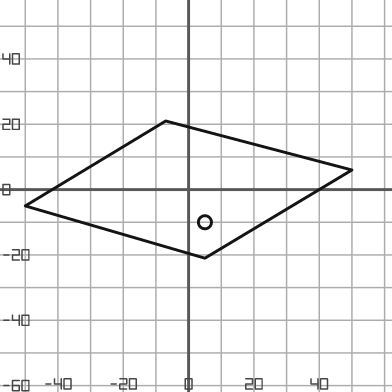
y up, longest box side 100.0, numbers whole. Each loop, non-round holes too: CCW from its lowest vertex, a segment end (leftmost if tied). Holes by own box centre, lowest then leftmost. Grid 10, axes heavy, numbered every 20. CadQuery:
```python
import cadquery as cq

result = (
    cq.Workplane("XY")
    .moveTo(5.0, -21.0)
    .lineTo(50.0, 6.0)
    .lineTo(-7.0, 21.0)
    .lineTo(-50.0, -5.0)
    .close()
    .moveTo(5.0, -10.0)
    .circle(2.0)
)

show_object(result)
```